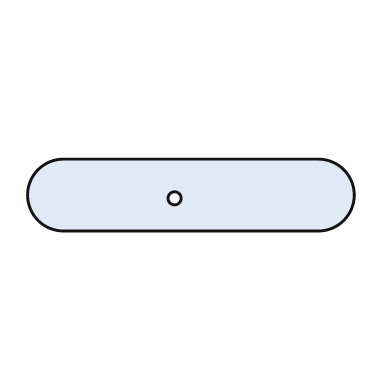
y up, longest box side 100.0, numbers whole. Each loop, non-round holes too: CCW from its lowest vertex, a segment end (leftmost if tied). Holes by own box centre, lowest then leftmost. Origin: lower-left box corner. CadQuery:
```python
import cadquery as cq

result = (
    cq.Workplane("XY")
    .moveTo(11.0, 0.0)
    .lineTo(89.0, 0.0)
    .threePointArc((100.0, 11.0), (89.0, 22.0))
    .lineTo(11.0, 22.0)
    .threePointArc((0.0, 11.0), (11.0, 0.0))
    .close()
    .moveTo(45.0, 10.0)
    .circle(2.0)
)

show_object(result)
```